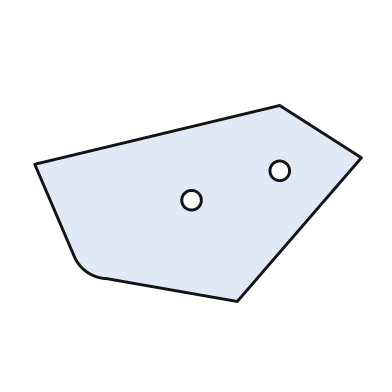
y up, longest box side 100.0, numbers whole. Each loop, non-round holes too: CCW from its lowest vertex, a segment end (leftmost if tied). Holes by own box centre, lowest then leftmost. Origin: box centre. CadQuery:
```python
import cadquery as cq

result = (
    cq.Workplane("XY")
    .moveTo(12.0, -30.0)
    .lineTo(50.0, 14.0)
    .lineTo(25.0, 30.0)
    .lineTo(-50.0, 12.0)
    .lineTo(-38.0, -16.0)
    .threePointArc((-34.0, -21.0), (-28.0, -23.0))
    .close()
    .moveTo(-2.0, 1.0)
    .circle(3.0)
    .moveTo(25.0, 10.0)
    .circle(3.0)
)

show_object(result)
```